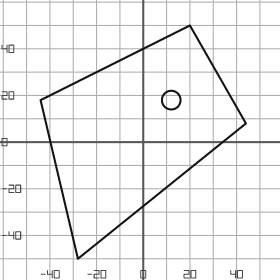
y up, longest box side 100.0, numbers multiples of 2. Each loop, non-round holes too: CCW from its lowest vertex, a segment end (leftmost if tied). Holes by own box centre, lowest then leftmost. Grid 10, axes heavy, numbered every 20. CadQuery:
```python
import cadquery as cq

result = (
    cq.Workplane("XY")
    .moveTo(-28.0, -50.0)
    .lineTo(44.0, 8.0)
    .lineTo(20.0, 50.0)
    .lineTo(-44.0, 18.0)
    .close()
    .moveTo(12.0, 18.0)
    .circle(4.0)
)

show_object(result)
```